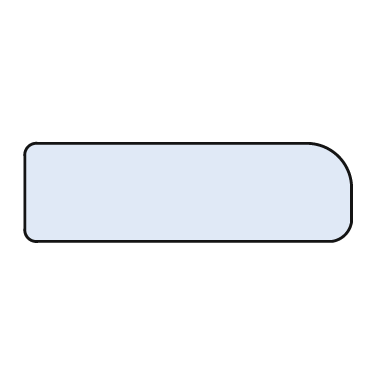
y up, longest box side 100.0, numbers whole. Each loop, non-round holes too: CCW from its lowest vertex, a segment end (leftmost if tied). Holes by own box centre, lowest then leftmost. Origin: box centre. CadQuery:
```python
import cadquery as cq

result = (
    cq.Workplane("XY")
    .moveTo(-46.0, -15.0)
    .lineTo(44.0, -15.0)
    .threePointArc((48.0, -13.0), (50.0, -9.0))
    .lineTo(50.0, 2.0)
    .threePointArc((46.0, 11.0), (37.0, 15.0))
    .lineTo(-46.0, 15.0)
    .threePointArc((-49.0, 14.0), (-50.0, 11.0))
    .lineTo(-50.0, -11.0)
    .threePointArc((-49.0, -14.0), (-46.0, -15.0))
    .close()
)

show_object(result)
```